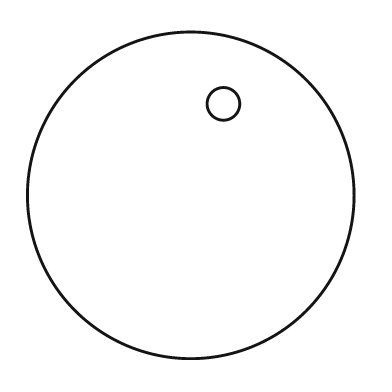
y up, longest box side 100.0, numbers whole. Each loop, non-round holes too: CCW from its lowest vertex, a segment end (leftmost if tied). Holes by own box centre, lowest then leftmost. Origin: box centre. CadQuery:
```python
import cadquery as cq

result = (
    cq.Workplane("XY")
    .moveTo(0.0, 0.0)
    .circle(50.0)
    .moveTo(10.0, 28.0)
    .circle(5.0)
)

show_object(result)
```